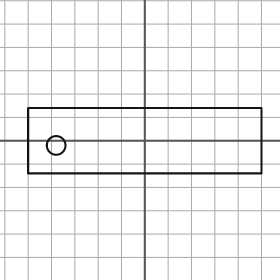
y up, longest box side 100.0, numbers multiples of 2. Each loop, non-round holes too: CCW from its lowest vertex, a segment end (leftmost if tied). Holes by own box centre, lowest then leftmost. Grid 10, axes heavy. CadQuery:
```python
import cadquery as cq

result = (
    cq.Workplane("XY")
    .moveTo(-50.0, -14.0)
    .lineTo(50.0, -14.0)
    .lineTo(50.0, 14.0)
    .lineTo(-50.0, 14.0)
    .close()
    .moveTo(-38.0, -2.0)
    .circle(4.0)
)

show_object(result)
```